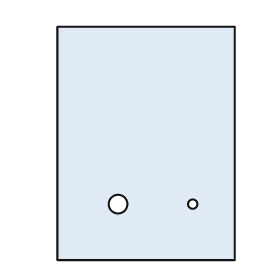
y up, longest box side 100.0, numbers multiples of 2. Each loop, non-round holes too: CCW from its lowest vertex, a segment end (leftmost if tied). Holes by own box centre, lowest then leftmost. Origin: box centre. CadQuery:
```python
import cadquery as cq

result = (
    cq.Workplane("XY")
    .moveTo(-38.0, -50.0)
    .lineTo(38.0, -50.0)
    .lineTo(38.0, 50.0)
    .lineTo(-38.0, 50.0)
    .close()
    .moveTo(-12.0, -26.0)
    .circle(4.0)
    .moveTo(20.0, -26.0)
    .circle(2.0)
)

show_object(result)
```